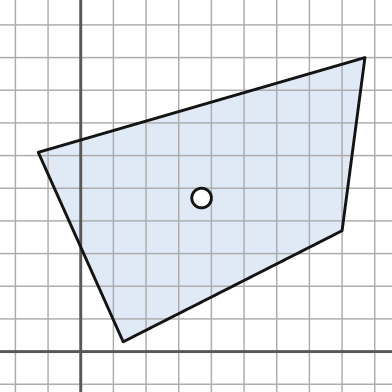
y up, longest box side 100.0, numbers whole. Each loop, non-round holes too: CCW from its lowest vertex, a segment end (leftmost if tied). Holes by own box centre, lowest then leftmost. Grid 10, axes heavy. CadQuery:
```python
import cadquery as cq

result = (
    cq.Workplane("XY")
    .moveTo(13.0, 3.0)
    .lineTo(80.0, 37.0)
    .lineTo(87.0, 90.0)
    .lineTo(-13.0, 61.0)
    .close()
    .moveTo(37.0, 47.0)
    .circle(3.0)
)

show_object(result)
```